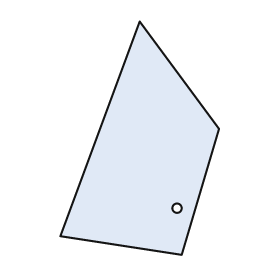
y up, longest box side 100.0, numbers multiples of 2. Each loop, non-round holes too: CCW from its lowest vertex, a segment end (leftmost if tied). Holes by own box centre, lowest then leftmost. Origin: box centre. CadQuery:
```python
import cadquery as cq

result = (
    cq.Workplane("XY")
    .moveTo(18.0, -50.0)
    .lineTo(34.0, 4.0)
    .lineTo(0.0, 50.0)
    .lineTo(-34.0, -42.0)
    .close()
    .moveTo(16.0, -30.0)
    .circle(2.0)
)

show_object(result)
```